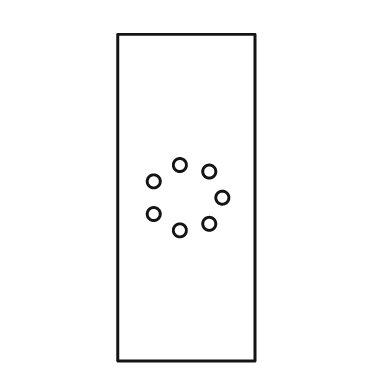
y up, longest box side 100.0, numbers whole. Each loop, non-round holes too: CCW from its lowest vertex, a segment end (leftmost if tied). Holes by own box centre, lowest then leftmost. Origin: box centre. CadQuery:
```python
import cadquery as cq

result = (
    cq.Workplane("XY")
    .moveTo(-21.0, -50.0)
    .lineTo(21.0, -50.0)
    .lineTo(21.0, 50.0)
    .lineTo(-21.0, 50.0)
    .close()
    .moveTo(-2.0, -10.0)
    .circle(2.0)
    .moveTo(7.0, -8.0)
    .circle(2.0)
    .moveTo(-10.0, -5.0)
    .circle(2.0)
    .moveTo(11.0, 0.0)
    .circle(2.0)
    .moveTo(-10.0, 5.0)
    .circle(2.0)
    .moveTo(7.0, 8.0)
    .circle(2.0)
    .moveTo(-2.0, 10.0)
    .circle(2.0)
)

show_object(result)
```